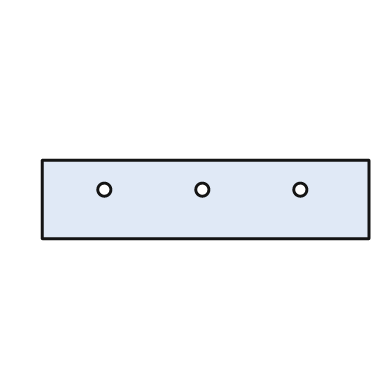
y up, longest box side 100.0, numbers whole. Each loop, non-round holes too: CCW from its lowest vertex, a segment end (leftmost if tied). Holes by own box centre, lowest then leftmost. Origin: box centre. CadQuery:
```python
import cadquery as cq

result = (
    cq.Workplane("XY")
    .moveTo(-50.0, -12.0)
    .lineTo(50.0, -12.0)
    .lineTo(50.0, 12.0)
    .lineTo(-50.0, 12.0)
    .close()
    .moveTo(-31.0, 3.0)
    .circle(2.0)
    .moveTo(-1.0, 3.0)
    .circle(2.0)
    .moveTo(29.0, 3.0)
    .circle(2.0)
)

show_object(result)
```